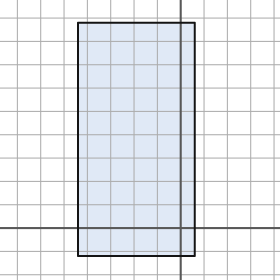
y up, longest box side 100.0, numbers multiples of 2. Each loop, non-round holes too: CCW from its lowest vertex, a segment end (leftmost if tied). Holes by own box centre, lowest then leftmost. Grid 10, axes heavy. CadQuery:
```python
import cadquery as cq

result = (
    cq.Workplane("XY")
    .moveTo(-44.0, -12.0)
    .lineTo(6.0, -12.0)
    .lineTo(6.0, 88.0)
    .lineTo(-44.0, 88.0)
    .close()
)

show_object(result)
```